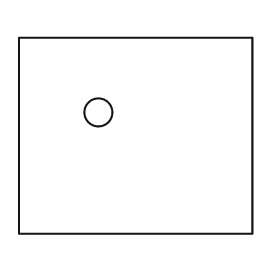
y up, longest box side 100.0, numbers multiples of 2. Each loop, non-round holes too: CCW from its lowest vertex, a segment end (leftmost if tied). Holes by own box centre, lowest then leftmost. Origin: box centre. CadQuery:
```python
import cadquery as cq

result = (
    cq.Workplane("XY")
    .moveTo(-50.0, -42.0)
    .lineTo(50.0, -42.0)
    .lineTo(50.0, 42.0)
    .lineTo(-50.0, 42.0)
    .close()
    .moveTo(-16.0, 10.0)
    .circle(6.0)
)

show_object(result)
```